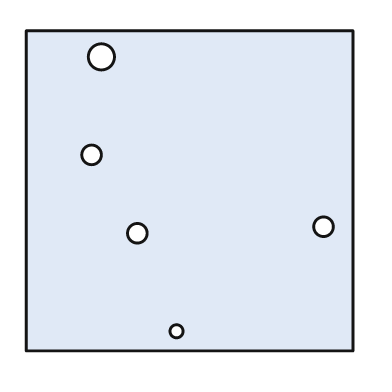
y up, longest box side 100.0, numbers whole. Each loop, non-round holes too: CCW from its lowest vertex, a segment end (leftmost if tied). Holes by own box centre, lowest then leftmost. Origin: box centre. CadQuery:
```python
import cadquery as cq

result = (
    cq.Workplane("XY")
    .moveTo(-50.0, -49.0)
    .lineTo(50.0, -49.0)
    .lineTo(50.0, 49.0)
    .lineTo(-50.0, 49.0)
    .close()
    .moveTo(-4.0, -43.0)
    .circle(2.0)
    .moveTo(-16.0, -13.0)
    .circle(3.0)
    .moveTo(41.0, -11.0)
    .circle(3.0)
    .moveTo(-30.0, 11.0)
    .circle(3.0)
    .moveTo(-27.0, 41.0)
    .circle(4.0)
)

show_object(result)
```